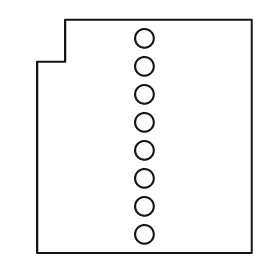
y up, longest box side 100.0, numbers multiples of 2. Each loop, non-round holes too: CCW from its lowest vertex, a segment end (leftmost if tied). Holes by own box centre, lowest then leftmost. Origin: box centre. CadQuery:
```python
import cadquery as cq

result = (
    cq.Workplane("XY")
    .moveTo(-46.0, -50.0)
    .lineTo(46.0, -50.0)
    .lineTo(46.0, 50.0)
    .lineTo(-34.0, 50.0)
    .lineTo(-34.0, 32.0)
    .lineTo(-46.0, 32.0)
    .close()
    .moveTo(0.0, -42.0)
    .circle(4.0)
    .moveTo(0.0, -30.0)
    .circle(4.0)
    .moveTo(0.0, -18.0)
    .circle(4.0)
    .moveTo(0.0, -6.0)
    .circle(4.0)
    .moveTo(0.0, 6.0)
    .circle(4.0)
    .moveTo(0.0, 18.0)
    .circle(4.0)
    .moveTo(0.0, 30.0)
    .circle(4.0)
    .moveTo(0.0, 42.0)
    .circle(4.0)
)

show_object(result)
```